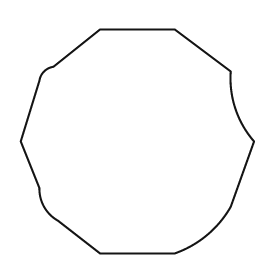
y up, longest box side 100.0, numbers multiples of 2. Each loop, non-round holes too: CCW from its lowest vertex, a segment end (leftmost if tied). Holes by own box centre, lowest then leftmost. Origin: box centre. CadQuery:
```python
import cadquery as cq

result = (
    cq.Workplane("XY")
    .moveTo(-16.0, -48.0)
    .lineTo(16.0, -48.0)
    .threePointArc((30.0, -40.0), (40.0, -28.0))
    .lineTo(50.0, 0.0)
    .threePointArc((42.0, 14.0), (40.0, 30.0))
    .lineTo(16.0, 48.0)
    .lineTo(-16.0, 48.0)
    .lineTo(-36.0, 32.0)
    .threePointArc((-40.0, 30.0), (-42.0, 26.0))
    .lineTo(-50.0, 0.0)
    .lineTo(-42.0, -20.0)
    .threePointArc((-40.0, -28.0), (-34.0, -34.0))
    .close()
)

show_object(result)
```